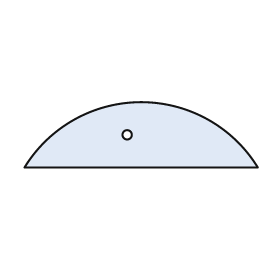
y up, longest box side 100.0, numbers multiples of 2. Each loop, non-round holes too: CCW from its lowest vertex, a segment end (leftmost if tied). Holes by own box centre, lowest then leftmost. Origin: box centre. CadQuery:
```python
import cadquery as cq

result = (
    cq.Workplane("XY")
    .moveTo(-50.0, -14.0)
    .lineTo(50.0, -14.0)
    .threePointArc((0.0, 14.0), (-50.0, -14.0))
    .close()
    .moveTo(-6.0, 0.0)
    .circle(2.0)
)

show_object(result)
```